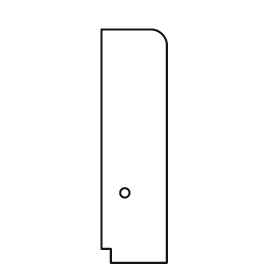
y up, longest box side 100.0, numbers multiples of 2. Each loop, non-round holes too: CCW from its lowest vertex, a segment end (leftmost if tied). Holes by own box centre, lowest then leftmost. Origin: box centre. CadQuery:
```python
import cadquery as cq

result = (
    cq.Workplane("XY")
    .moveTo(-10.0, -50.0)
    .lineTo(14.0, -50.0)
    .lineTo(14.0, 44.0)
    .threePointArc((12.0, 48.0), (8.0, 50.0))
    .lineTo(-14.0, 50.0)
    .lineTo(-14.0, -44.0)
    .lineTo(-10.0, -44.0)
    .close()
    .moveTo(-4.0, -20.0)
    .circle(2.0)
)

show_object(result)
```